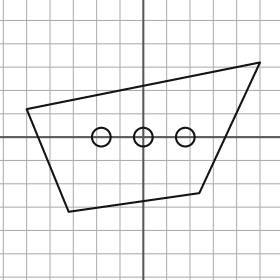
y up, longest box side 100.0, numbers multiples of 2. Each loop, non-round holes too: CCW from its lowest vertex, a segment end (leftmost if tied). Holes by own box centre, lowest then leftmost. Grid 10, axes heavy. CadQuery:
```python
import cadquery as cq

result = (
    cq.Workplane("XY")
    .moveTo(-32.0, -32.0)
    .lineTo(24.0, -24.0)
    .lineTo(50.0, 32.0)
    .lineTo(-50.0, 12.0)
    .close()
    .moveTo(-18.0, 0.0)
    .circle(4.0)
    .moveTo(0.0, 0.0)
    .circle(4.0)
    .moveTo(18.0, 0.0)
    .circle(4.0)
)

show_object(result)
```